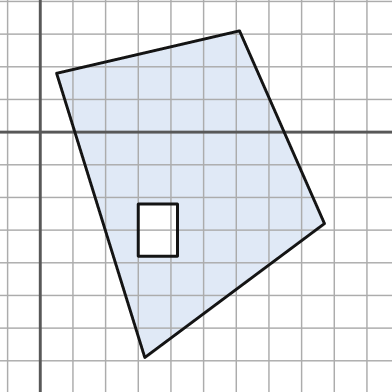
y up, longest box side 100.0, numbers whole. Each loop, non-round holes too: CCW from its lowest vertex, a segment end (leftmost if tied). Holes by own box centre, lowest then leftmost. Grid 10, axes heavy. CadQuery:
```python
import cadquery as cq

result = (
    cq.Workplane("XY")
    .moveTo(32.0, -69.0)
    .lineTo(87.0, -28.0)
    .lineTo(61.0, 31.0)
    .lineTo(5.0, 18.0)
    .close()
    .moveTo(30.0, -38.0)
    .lineTo(42.0, -38.0)
    .lineTo(42.0, -22.0)
    .lineTo(30.0, -22.0)
    .close()
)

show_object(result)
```